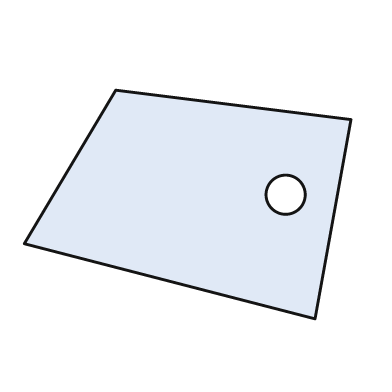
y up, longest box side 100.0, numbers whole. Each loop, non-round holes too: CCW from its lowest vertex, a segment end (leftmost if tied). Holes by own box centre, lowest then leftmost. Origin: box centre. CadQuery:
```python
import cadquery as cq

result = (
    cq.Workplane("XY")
    .moveTo(39.0, -35.0)
    .lineTo(50.0, 26.0)
    .lineTo(-22.0, 35.0)
    .lineTo(-50.0, -12.0)
    .close()
    .moveTo(30.0, 3.0)
    .circle(6.0)
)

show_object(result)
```